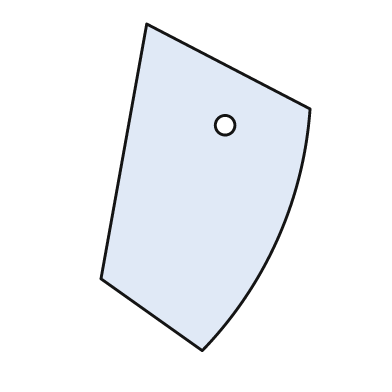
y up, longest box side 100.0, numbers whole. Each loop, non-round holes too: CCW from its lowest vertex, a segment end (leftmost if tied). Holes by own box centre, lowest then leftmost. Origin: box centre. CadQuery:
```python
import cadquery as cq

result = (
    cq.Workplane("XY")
    .moveTo(-1.0, -50.0)
    .threePointArc((22.0, -16.0), (32.0, 24.0))
    .lineTo(-18.0, 50.0)
    .lineTo(-32.0, -28.0)
    .close()
    .moveTo(6.0, 19.0)
    .circle(3.0)
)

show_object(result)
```